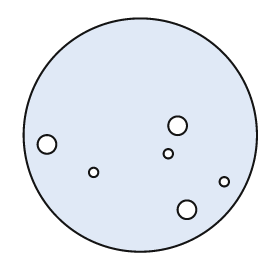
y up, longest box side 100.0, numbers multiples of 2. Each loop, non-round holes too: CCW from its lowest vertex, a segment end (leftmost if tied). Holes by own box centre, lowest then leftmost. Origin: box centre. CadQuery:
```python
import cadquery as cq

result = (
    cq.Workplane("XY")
    .moveTo(0.0, 0.0)
    .circle(50.0)
    .moveTo(20.0, -32.0)
    .circle(4.0)
    .moveTo(36.0, -20.0)
    .circle(2.0)
    .moveTo(-20.0, -16.0)
    .circle(2.0)
    .moveTo(12.0, -8.0)
    .circle(2.0)
    .moveTo(-40.0, -4.0)
    .circle(4.0)
    .moveTo(16.0, 4.0)
    .circle(4.0)
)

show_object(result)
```